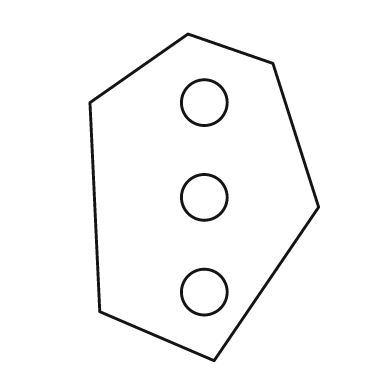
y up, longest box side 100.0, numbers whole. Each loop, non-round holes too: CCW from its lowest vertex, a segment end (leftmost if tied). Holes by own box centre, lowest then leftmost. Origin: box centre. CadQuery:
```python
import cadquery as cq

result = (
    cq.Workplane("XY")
    .moveTo(3.0, -50.0)
    .lineTo(35.0, -3.0)
    .lineTo(21.0, 41.0)
    .lineTo(-5.0, 50.0)
    .lineTo(-35.0, 29.0)
    .lineTo(-32.0, -35.0)
    .close()
    .moveTo(0.0, -29.0)
    .circle(7.0)
    .moveTo(0.0, 0.0)
    .circle(7.0)
    .moveTo(0.0, 29.0)
    .circle(7.0)
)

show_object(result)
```